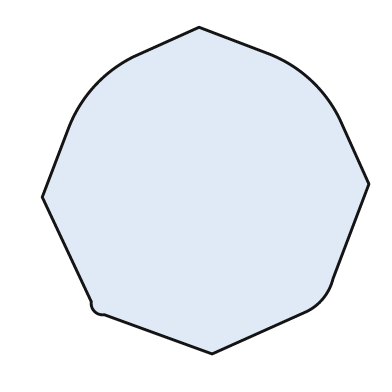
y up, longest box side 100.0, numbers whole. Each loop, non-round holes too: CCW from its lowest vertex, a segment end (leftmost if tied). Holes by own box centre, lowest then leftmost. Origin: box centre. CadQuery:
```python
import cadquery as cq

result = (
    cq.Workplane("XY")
    .moveTo(2.0, -50.0)
    .lineTo(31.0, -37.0)
    .threePointArc((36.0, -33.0), (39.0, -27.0))
    .lineTo(50.0, 2.0)
    .lineTo(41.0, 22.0)
    .threePointArc((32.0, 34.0), (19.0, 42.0))
    .lineTo(-2.0, 50.0)
    .lineTo(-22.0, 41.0)
    .threePointArc((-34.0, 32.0), (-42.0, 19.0))
    .lineTo(-50.0, -2.0)
    .lineTo(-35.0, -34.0)
    .threePointArc((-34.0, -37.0), (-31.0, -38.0))
    .close()
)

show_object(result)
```